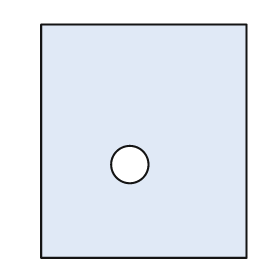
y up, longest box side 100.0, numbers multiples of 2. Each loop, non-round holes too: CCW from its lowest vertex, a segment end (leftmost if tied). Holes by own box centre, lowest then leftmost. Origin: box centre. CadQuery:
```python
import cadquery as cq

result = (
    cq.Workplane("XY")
    .moveTo(-44.0, -50.0)
    .lineTo(44.0, -50.0)
    .lineTo(44.0, 50.0)
    .lineTo(-44.0, 50.0)
    .close()
    .moveTo(-6.0, -10.0)
    .circle(8.0)
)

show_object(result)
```